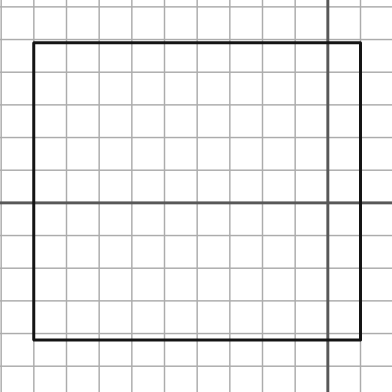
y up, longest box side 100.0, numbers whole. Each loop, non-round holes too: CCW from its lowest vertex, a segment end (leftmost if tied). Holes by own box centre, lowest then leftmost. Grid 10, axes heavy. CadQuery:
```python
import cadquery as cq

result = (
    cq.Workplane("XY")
    .moveTo(-90.0, -42.0)
    .lineTo(10.0, -42.0)
    .lineTo(10.0, 49.0)
    .lineTo(-90.0, 49.0)
    .close()
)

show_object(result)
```